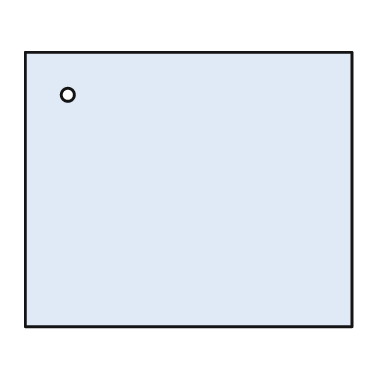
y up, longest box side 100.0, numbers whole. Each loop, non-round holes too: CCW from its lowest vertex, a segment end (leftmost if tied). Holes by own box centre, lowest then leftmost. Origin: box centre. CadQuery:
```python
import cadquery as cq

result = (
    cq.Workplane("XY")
    .moveTo(-50.0, -42.0)
    .lineTo(50.0, -42.0)
    .lineTo(50.0, 42.0)
    .lineTo(-50.0, 42.0)
    .close()
    .moveTo(-37.0, 29.0)
    .circle(2.0)
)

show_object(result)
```